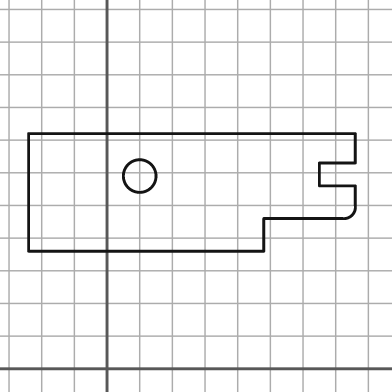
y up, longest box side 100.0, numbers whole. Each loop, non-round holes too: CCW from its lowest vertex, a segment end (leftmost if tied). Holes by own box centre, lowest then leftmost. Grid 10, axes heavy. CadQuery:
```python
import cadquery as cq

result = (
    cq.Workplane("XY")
    .moveTo(-24.0, 36.0)
    .lineTo(48.0, 36.0)
    .lineTo(48.0, 46.0)
    .lineTo(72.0, 46.0)
    .threePointArc((75.0, 47.0), (76.0, 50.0))
    .lineTo(76.0, 56.0)
    .lineTo(65.0, 56.0)
    .lineTo(65.0, 63.0)
    .lineTo(76.0, 63.0)
    .lineTo(76.0, 72.0)
    .lineTo(-24.0, 72.0)
    .close()
    .moveTo(10.0, 59.0)
    .circle(5.0)
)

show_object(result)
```